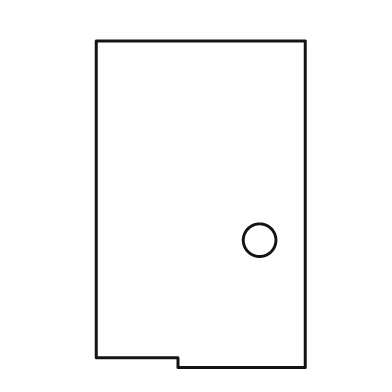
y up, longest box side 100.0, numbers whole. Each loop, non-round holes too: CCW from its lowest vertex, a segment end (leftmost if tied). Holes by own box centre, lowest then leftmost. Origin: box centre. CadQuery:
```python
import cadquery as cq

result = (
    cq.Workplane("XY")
    .moveTo(-7.0, -50.0)
    .lineTo(32.0, -50.0)
    .lineTo(32.0, 50.0)
    .lineTo(-32.0, 50.0)
    .lineTo(-32.0, -47.0)
    .lineTo(-7.0, -47.0)
    .close()
    .moveTo(18.0, -11.0)
    .circle(5.0)
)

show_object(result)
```